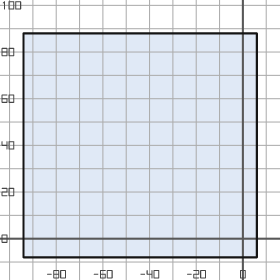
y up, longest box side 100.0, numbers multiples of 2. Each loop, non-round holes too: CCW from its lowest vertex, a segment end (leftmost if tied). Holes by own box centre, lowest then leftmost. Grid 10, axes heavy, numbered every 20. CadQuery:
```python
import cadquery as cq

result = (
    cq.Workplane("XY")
    .moveTo(-94.0, -8.0)
    .lineTo(6.0, -8.0)
    .lineTo(6.0, 88.0)
    .lineTo(-94.0, 88.0)
    .close()
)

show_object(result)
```